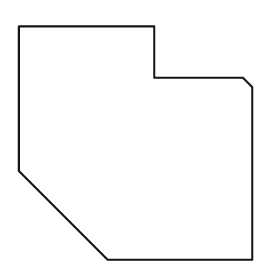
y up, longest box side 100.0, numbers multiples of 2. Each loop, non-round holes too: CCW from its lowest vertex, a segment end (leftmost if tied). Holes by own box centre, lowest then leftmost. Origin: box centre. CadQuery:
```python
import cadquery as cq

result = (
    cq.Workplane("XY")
    .moveTo(-12.0, -50.0)
    .lineTo(50.0, -50.0)
    .lineTo(50.0, 24.0)
    .lineTo(46.0, 28.0)
    .lineTo(8.0, 28.0)
    .lineTo(8.0, 50.0)
    .lineTo(-50.0, 50.0)
    .lineTo(-50.0, -12.0)
    .close()
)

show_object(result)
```